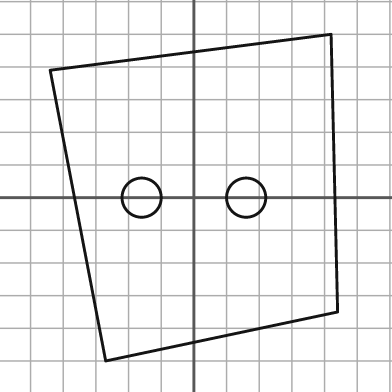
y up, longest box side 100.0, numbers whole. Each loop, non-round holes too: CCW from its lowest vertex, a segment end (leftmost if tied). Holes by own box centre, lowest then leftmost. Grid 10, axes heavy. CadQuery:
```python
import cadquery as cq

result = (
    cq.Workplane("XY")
    .moveTo(-27.0, -50.0)
    .lineTo(44.0, -35.0)
    .lineTo(42.0, 50.0)
    .lineTo(-44.0, 39.0)
    .close()
    .moveTo(-16.0, 0.0)
    .circle(6.0)
    .moveTo(16.0, 0.0)
    .circle(6.0)
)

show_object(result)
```